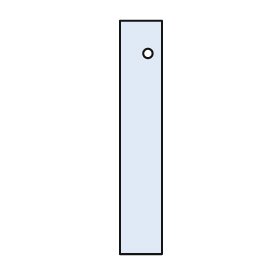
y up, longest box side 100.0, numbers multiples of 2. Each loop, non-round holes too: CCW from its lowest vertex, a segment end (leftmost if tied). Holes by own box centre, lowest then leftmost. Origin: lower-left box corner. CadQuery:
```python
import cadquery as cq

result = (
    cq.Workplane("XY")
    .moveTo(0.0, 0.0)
    .lineTo(18.0, 0.0)
    .lineTo(18.0, 100.0)
    .lineTo(0.0, 100.0)
    .close()
    .moveTo(12.0, 86.0)
    .circle(2.0)
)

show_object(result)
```